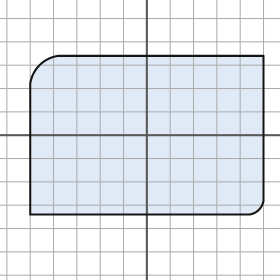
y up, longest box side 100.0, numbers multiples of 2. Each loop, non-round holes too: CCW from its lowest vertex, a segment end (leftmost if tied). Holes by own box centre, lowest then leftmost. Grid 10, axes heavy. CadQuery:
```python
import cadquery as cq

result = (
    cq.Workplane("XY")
    .moveTo(-50.0, -34.0)
    .lineTo(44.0, -34.0)
    .threePointArc((48.0, -32.0), (50.0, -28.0))
    .lineTo(50.0, 34.0)
    .lineTo(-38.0, 34.0)
    .threePointArc((-46.0, 30.0), (-50.0, 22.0))
    .close()
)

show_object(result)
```